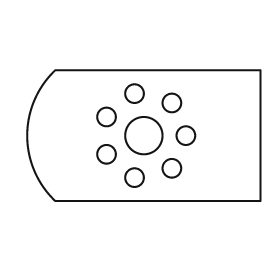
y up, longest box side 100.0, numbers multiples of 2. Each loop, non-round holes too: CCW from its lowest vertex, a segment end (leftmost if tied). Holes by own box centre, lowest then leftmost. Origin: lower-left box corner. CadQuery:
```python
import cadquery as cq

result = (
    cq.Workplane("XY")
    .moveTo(12.0, 0.0)
    .lineTo(100.0, 0.0)
    .lineTo(100.0, 56.0)
    .lineTo(12.0, 56.0)
    .threePointArc((0.0, 28.0), (12.0, 0.0))
    .close()
    .moveTo(46.0, 10.0)
    .circle(4.0)
    .moveTo(62.0, 14.0)
    .circle(4.0)
    .moveTo(34.0, 20.0)
    .circle(4.0)
    .moveTo(50.0, 28.0)
    .circle(8.0)
    .moveTo(68.0, 28.0)
    .circle(4.0)
    .moveTo(34.0, 36.0)
    .circle(4.0)
    .moveTo(62.0, 42.0)
    .circle(4.0)
    .moveTo(46.0, 46.0)
    .circle(4.0)
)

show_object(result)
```